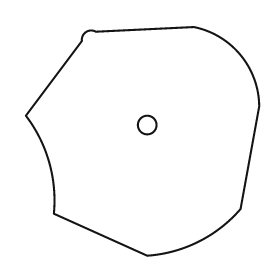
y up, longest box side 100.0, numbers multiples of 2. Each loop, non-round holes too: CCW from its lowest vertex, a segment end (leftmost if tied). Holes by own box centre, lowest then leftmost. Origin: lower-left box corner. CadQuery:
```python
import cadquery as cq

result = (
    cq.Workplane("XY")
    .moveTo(52.0, 0.0)
    .threePointArc((74.0, 6.0), (92.0, 20.0))
    .lineTo(100.0, 64.0)
    .threePointArc((92.0, 86.0), (72.0, 98.0))
    .lineTo(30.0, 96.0)
    .threePointArc((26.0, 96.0), (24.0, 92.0))
    .lineTo(0.0, 60.0)
    .threePointArc((10.0, 40.0), (12.0, 18.0))
    .close()
    .moveTo(52.0, 56.0)
    .circle(4.0)
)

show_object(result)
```